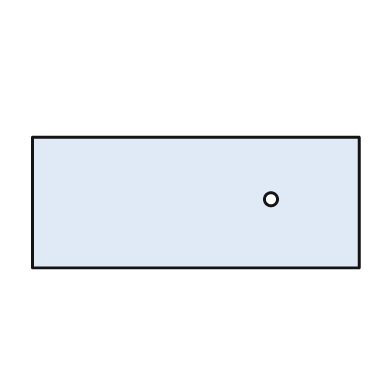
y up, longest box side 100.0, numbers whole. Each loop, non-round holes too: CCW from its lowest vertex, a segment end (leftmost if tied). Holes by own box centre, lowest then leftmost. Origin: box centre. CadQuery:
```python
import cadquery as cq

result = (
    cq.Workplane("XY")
    .moveTo(-50.0, -20.0)
    .lineTo(50.0, -20.0)
    .lineTo(50.0, 20.0)
    .lineTo(-50.0, 20.0)
    .close()
    .moveTo(23.0, 1.0)
    .circle(2.0)
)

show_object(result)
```